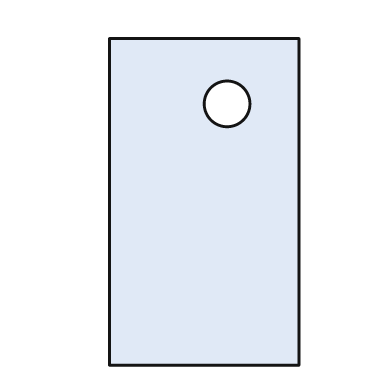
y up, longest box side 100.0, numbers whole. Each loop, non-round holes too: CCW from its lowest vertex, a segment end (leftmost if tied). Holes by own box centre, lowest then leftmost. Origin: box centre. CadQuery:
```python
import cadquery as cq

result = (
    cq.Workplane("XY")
    .moveTo(-29.0, -50.0)
    .lineTo(29.0, -50.0)
    .lineTo(29.0, 50.0)
    .lineTo(-29.0, 50.0)
    .close()
    .moveTo(7.0, 30.0)
    .circle(7.0)
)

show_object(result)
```